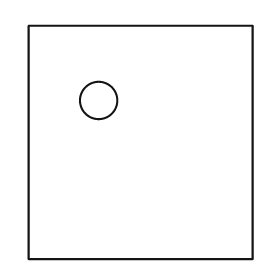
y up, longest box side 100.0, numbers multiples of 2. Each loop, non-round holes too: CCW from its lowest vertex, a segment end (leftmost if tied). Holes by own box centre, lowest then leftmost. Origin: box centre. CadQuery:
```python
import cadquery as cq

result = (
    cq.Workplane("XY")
    .moveTo(-48.0, -50.0)
    .lineTo(48.0, -50.0)
    .lineTo(48.0, 50.0)
    .lineTo(-48.0, 50.0)
    .close()
    .moveTo(-18.0, 18.0)
    .circle(8.0)
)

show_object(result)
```